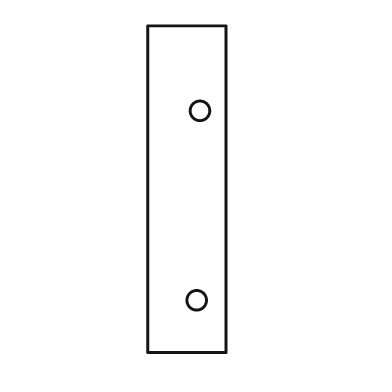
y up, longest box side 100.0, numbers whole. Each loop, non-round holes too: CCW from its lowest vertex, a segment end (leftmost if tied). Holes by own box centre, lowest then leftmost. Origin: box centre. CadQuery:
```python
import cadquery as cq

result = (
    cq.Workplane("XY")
    .moveTo(-12.0, -50.0)
    .lineTo(12.0, -50.0)
    .lineTo(12.0, 50.0)
    .lineTo(-12.0, 50.0)
    .close()
    .moveTo(3.0, -34.0)
    .circle(3.0)
    .moveTo(4.0, 24.0)
    .circle(3.0)
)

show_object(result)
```